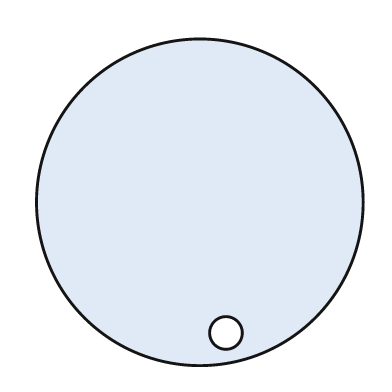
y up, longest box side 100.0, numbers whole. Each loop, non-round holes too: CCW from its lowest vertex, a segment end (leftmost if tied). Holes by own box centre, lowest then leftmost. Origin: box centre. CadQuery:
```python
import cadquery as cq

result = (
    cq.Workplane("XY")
    .moveTo(0.0, 0.0)
    .circle(50.0)
    .moveTo(8.0, -40.0)
    .circle(5.0)
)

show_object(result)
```